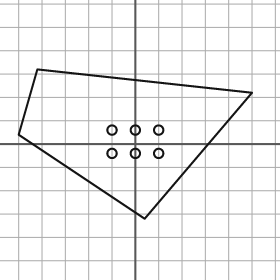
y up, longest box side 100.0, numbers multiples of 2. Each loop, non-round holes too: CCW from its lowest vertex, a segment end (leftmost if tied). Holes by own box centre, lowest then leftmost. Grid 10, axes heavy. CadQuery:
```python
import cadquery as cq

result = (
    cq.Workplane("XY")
    .moveTo(4.0, -32.0)
    .lineTo(50.0, 22.0)
    .lineTo(-42.0, 32.0)
    .lineTo(-50.0, 4.0)
    .close()
    .moveTo(-10.0, -4.0)
    .circle(2.0)
    .moveTo(0.0, -4.0)
    .circle(2.0)
    .moveTo(10.0, -4.0)
    .circle(2.0)
    .moveTo(-10.0, 6.0)
    .circle(2.0)
    .moveTo(0.0, 6.0)
    .circle(2.0)
    .moveTo(10.0, 6.0)
    .circle(2.0)
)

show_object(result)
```